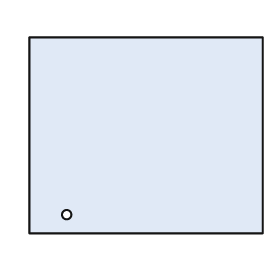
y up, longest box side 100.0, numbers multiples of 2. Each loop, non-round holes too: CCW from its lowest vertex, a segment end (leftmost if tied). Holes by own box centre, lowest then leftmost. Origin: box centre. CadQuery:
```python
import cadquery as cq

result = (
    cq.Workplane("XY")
    .moveTo(-50.0, -42.0)
    .lineTo(50.0, -42.0)
    .lineTo(50.0, 42.0)
    .lineTo(-50.0, 42.0)
    .close()
    .moveTo(-34.0, -34.0)
    .circle(2.0)
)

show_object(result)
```